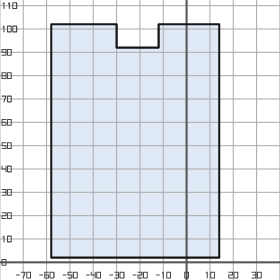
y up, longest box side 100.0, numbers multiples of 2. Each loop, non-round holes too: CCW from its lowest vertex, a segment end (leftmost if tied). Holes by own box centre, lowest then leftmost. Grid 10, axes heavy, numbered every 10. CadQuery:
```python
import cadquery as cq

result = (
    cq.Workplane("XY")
    .moveTo(-58.0, 2.0)
    .lineTo(14.0, 2.0)
    .lineTo(14.0, 102.0)
    .lineTo(-12.0, 102.0)
    .lineTo(-12.0, 92.0)
    .lineTo(-30.0, 92.0)
    .lineTo(-30.0, 102.0)
    .lineTo(-58.0, 102.0)
    .close()
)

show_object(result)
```